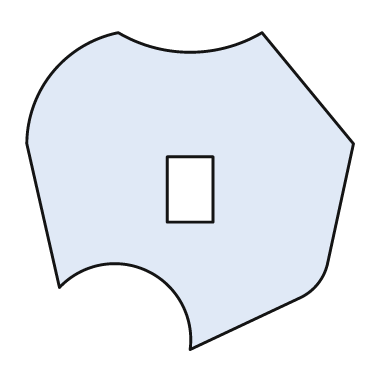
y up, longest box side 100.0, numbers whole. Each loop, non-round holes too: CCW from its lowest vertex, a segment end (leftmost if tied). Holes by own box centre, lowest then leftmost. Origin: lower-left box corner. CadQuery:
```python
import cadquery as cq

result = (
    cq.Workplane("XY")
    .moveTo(50.0, 0.0)
    .lineTo(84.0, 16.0)
    .threePointArc((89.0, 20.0), (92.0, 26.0))
    .lineTo(100.0, 63.0)
    .lineTo(72.0, 97.0)
    .threePointArc((50.0, 91.0), (28.0, 97.0))
    .threePointArc((8.0, 85.0), (0.0, 63.0))
    .lineTo(10.0, 19.0)
    .threePointArc((37.0, 24.0), (50.0, 0.0))
    .close()
    .moveTo(43.0, 39.0)
    .lineTo(57.0, 39.0)
    .lineTo(57.0, 59.0)
    .lineTo(43.0, 59.0)
    .close()
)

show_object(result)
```